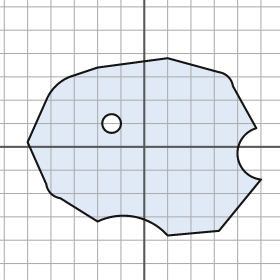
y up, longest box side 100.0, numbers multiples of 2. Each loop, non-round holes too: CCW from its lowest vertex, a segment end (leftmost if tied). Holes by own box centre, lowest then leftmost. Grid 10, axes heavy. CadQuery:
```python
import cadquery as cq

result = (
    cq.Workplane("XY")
    .moveTo(10.0, -38.0)
    .lineTo(32.0, -36.0)
    .lineTo(50.0, -14.0)
    .threePointArc((40.0, -4.0), (48.0, 8.0))
    .lineTo(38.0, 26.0)
    .threePointArc((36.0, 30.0), (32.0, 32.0))
    .lineTo(10.0, 38.0)
    .lineTo(-20.0, 34.0)
    .lineTo(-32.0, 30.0)
    .threePointArc((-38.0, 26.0), (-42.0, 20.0))
    .lineTo(-50.0, 2.0)
    .lineTo(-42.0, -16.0)
    .threePointArc((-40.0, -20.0), (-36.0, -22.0))
    .lineTo(-20.0, -32.0)
    .threePointArc((-4.0, -30.0), (10.0, -38.0))
    .close()
    .moveTo(-14.0, 10.0)
    .circle(4.0)
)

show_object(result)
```